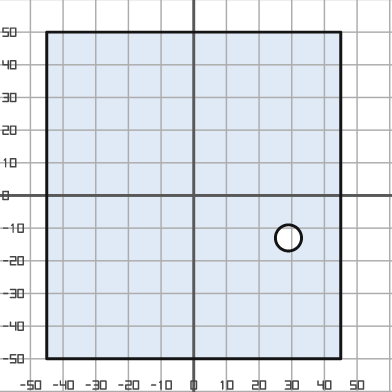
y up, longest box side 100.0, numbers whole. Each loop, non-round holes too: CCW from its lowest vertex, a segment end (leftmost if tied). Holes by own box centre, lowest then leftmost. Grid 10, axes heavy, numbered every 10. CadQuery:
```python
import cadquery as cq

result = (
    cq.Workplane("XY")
    .moveTo(-45.0, -50.0)
    .lineTo(45.0, -50.0)
    .lineTo(45.0, 50.0)
    .lineTo(-45.0, 50.0)
    .close()
    .moveTo(29.0, -13.0)
    .circle(4.0)
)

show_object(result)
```